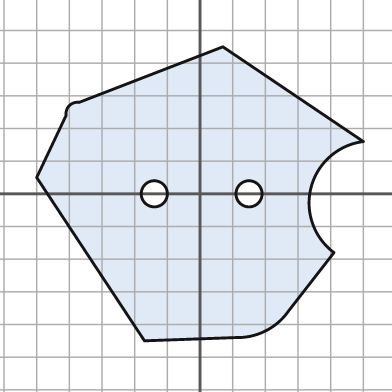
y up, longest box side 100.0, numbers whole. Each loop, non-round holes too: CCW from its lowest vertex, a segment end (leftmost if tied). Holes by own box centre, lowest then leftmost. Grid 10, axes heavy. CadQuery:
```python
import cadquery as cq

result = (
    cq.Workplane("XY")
    .moveTo(-17.0, -45.0)
    .lineTo(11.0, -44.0)
    .threePointArc((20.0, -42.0), (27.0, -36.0))
    .lineTo(41.0, -18.0)
    .threePointArc((34.0, 2.0), (50.0, 16.0))
    .lineTo(7.0, 45.0)
    .lineTo(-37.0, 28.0)
    .threePointArc((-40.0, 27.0), (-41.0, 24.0))
    .lineTo(-50.0, 5.0)
    .close()
    .moveTo(-14.0, 0.0)
    .circle(4.0)
    .moveTo(15.0, 0.0)
    .circle(4.0)
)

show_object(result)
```